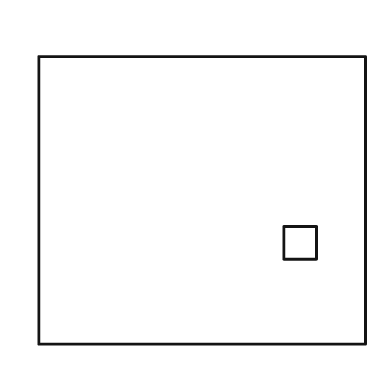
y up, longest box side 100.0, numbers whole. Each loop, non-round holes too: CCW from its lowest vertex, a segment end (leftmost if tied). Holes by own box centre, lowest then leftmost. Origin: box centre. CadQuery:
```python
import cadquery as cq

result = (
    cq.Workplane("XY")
    .moveTo(-50.0, -44.0)
    .lineTo(50.0, -44.0)
    .lineTo(50.0, 44.0)
    .lineTo(-50.0, 44.0)
    .close()
    .moveTo(25.0, -18.0)
    .lineTo(35.0, -18.0)
    .lineTo(35.0, -8.0)
    .lineTo(25.0, -8.0)
    .close()
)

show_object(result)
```